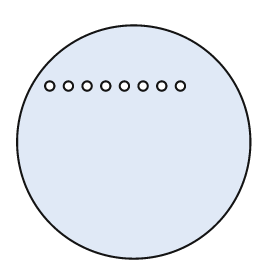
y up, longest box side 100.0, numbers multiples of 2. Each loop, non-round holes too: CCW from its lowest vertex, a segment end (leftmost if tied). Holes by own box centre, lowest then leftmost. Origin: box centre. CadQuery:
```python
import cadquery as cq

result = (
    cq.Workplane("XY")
    .moveTo(0.0, 0.0)
    .circle(50.0)
    .moveTo(-36.0, 24.0)
    .circle(2.0)
    .moveTo(-28.0, 24.0)
    .circle(2.0)
    .moveTo(-20.0, 24.0)
    .circle(2.0)
    .moveTo(-12.0, 24.0)
    .circle(2.0)
    .moveTo(-4.0, 24.0)
    .circle(2.0)
    .moveTo(4.0, 24.0)
    .circle(2.0)
    .moveTo(12.0, 24.0)
    .circle(2.0)
    .moveTo(20.0, 24.0)
    .circle(2.0)
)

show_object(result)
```